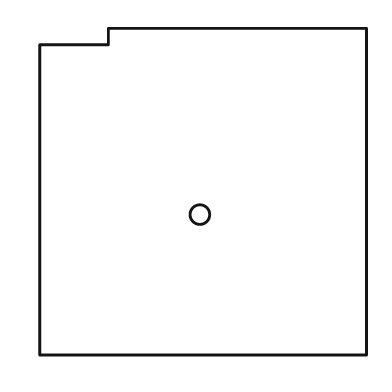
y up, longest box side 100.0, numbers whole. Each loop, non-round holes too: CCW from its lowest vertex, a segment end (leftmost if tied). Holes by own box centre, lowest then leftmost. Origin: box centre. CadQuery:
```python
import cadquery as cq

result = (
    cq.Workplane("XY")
    .moveTo(-50.0, -50.0)
    .lineTo(50.0, -50.0)
    .lineTo(50.0, 50.0)
    .lineTo(-29.0, 50.0)
    .lineTo(-29.0, 45.0)
    .lineTo(-50.0, 45.0)
    .close()
    .moveTo(-1.0, -7.0)
    .circle(3.0)
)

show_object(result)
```